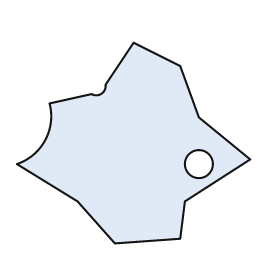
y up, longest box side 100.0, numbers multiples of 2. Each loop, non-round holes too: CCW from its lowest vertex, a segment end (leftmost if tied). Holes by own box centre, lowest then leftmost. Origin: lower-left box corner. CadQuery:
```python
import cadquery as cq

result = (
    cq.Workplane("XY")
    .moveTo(42.0, 0.0)
    .lineTo(70.0, 2.0)
    .lineTo(72.0, 18.0)
    .lineTo(100.0, 36.0)
    .lineTo(78.0, 54.0)
    .lineTo(70.0, 76.0)
    .lineTo(50.0, 86.0)
    .lineTo(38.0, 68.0)
    .threePointArc((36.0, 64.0), (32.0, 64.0))
    .lineTo(14.0, 60.0)
    .threePointArc((12.0, 44.0), (0.0, 34.0))
    .lineTo(26.0, 18.0)
    .close()
    .moveTo(78.0, 34.0)
    .circle(6.0)
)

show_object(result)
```